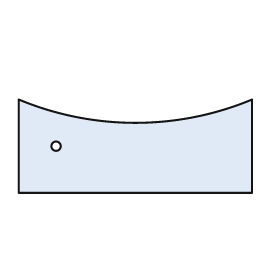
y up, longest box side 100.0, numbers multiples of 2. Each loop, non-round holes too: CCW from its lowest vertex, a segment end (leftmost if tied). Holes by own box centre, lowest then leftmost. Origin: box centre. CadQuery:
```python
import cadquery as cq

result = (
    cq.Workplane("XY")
    .moveTo(-50.0, -20.0)
    .lineTo(50.0, -20.0)
    .lineTo(50.0, 20.0)
    .threePointArc((0.0, 10.0), (-50.0, 20.0))
    .close()
    .moveTo(-34.0, 0.0)
    .circle(2.0)
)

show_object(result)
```